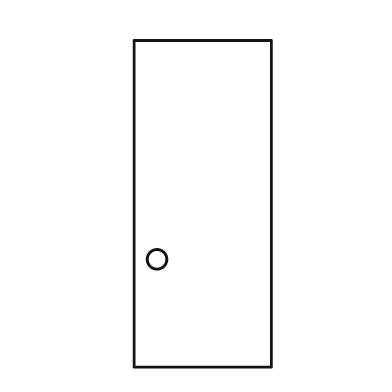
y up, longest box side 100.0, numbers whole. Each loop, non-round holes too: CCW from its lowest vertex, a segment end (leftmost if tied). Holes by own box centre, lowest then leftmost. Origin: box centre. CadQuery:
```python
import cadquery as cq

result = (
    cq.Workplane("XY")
    .moveTo(-21.0, -50.0)
    .lineTo(21.0, -50.0)
    .lineTo(21.0, 50.0)
    .lineTo(-21.0, 50.0)
    .close()
    .moveTo(-14.0, -17.0)
    .circle(3.0)
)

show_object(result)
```